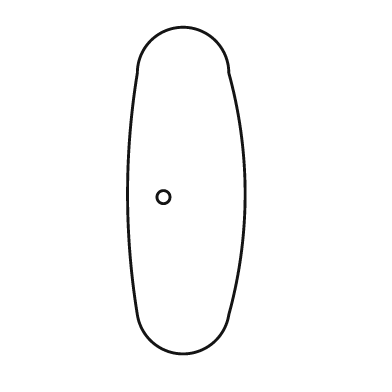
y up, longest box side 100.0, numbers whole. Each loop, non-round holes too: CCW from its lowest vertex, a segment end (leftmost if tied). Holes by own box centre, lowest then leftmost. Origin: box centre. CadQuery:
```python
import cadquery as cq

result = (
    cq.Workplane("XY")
    .moveTo(-15.0, -38.0)
    .threePointArc((-1.0, -50.0), (13.0, -38.0))
    .threePointArc((18.0, -1.0), (13.0, 36.0))
    .threePointArc((-1.0, 50.0), (-15.0, 36.0))
    .threePointArc((-18.0, -1.0), (-15.0, -38.0))
    .close()
    .moveTo(-7.0, -2.0)
    .circle(2.0)
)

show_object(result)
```